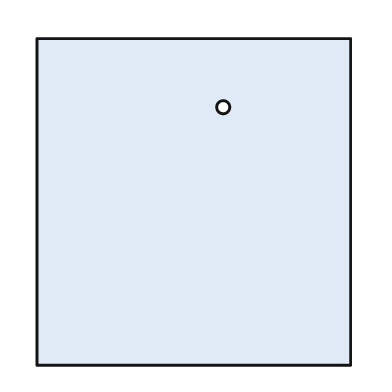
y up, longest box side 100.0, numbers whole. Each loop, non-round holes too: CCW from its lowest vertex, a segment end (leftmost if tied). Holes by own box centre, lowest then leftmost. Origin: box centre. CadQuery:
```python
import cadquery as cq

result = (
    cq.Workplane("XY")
    .moveTo(-48.0, -50.0)
    .lineTo(48.0, -50.0)
    .lineTo(48.0, 50.0)
    .lineTo(-48.0, 50.0)
    .close()
    .moveTo(9.0, 29.0)
    .circle(2.0)
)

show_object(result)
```